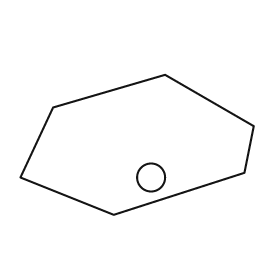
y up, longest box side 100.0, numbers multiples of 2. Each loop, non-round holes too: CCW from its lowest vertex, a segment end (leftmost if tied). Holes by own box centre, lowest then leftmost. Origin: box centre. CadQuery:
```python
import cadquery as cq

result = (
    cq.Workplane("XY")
    .moveTo(-10.0, -30.0)
    .lineTo(46.0, -12.0)
    .lineTo(50.0, 8.0)
    .lineTo(12.0, 30.0)
    .lineTo(-36.0, 16.0)
    .lineTo(-50.0, -14.0)
    .close()
    .moveTo(6.0, -14.0)
    .circle(6.0)
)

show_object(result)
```